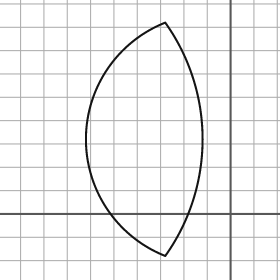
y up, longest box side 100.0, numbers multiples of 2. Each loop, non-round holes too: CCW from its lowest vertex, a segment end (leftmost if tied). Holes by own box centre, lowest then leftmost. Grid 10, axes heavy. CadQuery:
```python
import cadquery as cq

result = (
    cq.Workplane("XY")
    .moveTo(-28.0, -18.0)
    .threePointArc((-12.0, 32.0), (-28.0, 82.0))
    .threePointArc((-62.0, 32.0), (-28.0, -18.0))
    .close()
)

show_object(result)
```